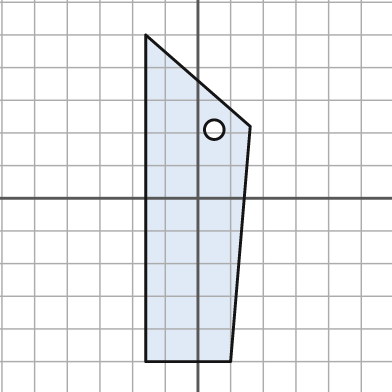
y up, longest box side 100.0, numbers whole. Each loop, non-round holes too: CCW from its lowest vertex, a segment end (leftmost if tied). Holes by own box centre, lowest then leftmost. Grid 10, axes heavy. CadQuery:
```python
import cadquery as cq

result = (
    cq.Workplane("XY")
    .moveTo(-16.0, -50.0)
    .lineTo(10.0, -50.0)
    .lineTo(16.0, 22.0)
    .lineTo(-16.0, 50.0)
    .close()
    .moveTo(5.0, 21.0)
    .circle(3.0)
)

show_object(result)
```